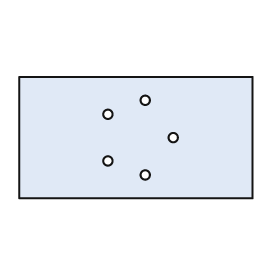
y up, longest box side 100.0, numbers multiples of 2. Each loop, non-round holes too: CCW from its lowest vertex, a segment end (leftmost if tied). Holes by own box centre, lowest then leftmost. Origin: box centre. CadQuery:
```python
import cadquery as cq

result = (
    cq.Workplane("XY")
    .moveTo(-50.0, -26.0)
    .lineTo(50.0, -26.0)
    .lineTo(50.0, 26.0)
    .lineTo(-50.0, 26.0)
    .close()
    .moveTo(4.0, -16.0)
    .circle(2.0)
    .moveTo(-12.0, -10.0)
    .circle(2.0)
    .moveTo(16.0, 0.0)
    .circle(2.0)
    .moveTo(-12.0, 10.0)
    .circle(2.0)
    .moveTo(4.0, 16.0)
    .circle(2.0)
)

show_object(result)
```